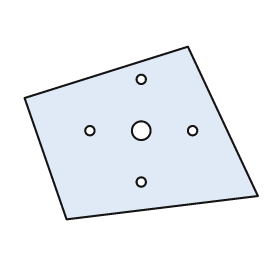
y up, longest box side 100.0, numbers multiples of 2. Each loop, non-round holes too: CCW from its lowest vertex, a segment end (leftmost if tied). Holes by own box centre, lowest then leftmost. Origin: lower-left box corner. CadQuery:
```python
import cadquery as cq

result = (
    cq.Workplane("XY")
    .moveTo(18.0, 0.0)
    .lineTo(100.0, 10.0)
    .lineTo(70.0, 74.0)
    .lineTo(0.0, 52.0)
    .close()
    .moveTo(50.0, 16.0)
    .circle(2.0)
    .moveTo(28.0, 38.0)
    .circle(2.0)
    .moveTo(50.0, 38.0)
    .circle(4.0)
    .moveTo(72.0, 38.0)
    .circle(2.0)
    .moveTo(50.0, 60.0)
    .circle(2.0)
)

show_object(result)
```